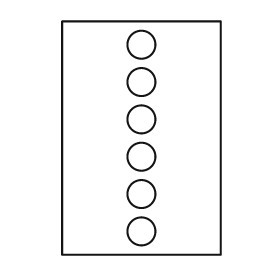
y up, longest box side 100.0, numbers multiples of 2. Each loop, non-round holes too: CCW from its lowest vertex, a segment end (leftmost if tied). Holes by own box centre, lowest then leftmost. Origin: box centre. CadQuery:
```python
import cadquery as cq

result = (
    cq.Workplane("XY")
    .moveTo(-34.0, -50.0)
    .lineTo(34.0, -50.0)
    .lineTo(34.0, 50.0)
    .lineTo(-34.0, 50.0)
    .close()
    .moveTo(0.0, -40.0)
    .circle(6.0)
    .moveTo(0.0, -24.0)
    .circle(6.0)
    .moveTo(0.0, -8.0)
    .circle(6.0)
    .moveTo(0.0, 8.0)
    .circle(6.0)
    .moveTo(0.0, 24.0)
    .circle(6.0)
    .moveTo(0.0, 40.0)
    .circle(6.0)
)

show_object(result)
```